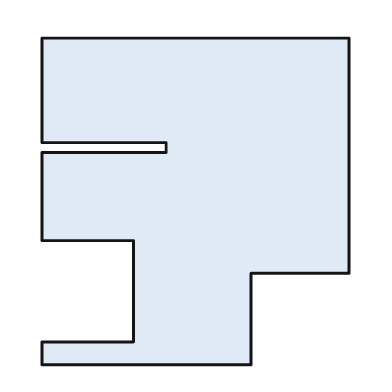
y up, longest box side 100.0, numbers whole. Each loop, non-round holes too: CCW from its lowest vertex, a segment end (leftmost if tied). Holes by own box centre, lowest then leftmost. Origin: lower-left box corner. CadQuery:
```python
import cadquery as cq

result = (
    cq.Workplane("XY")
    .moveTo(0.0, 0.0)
    .lineTo(64.0, 0.0)
    .lineTo(64.0, 28.0)
    .lineTo(94.0, 28.0)
    .lineTo(94.0, 100.0)
    .lineTo(0.0, 100.0)
    .lineTo(0.0, 68.0)
    .lineTo(38.0, 68.0)
    .lineTo(38.0, 65.0)
    .lineTo(0.0, 65.0)
    .lineTo(0.0, 38.0)
    .lineTo(28.0, 38.0)
    .lineTo(28.0, 7.0)
    .lineTo(0.0, 7.0)
    .close()
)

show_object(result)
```